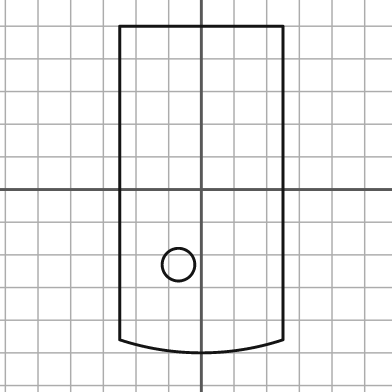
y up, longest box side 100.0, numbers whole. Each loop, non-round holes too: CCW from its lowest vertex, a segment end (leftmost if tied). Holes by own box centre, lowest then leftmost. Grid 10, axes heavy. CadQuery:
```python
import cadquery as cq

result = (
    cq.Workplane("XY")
    .moveTo(-25.0, -46.0)
    .threePointArc((0.0, -50.0), (25.0, -46.0))
    .lineTo(25.0, 50.0)
    .lineTo(-25.0, 50.0)
    .close()
    .moveTo(-7.0, -23.0)
    .circle(5.0)
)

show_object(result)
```